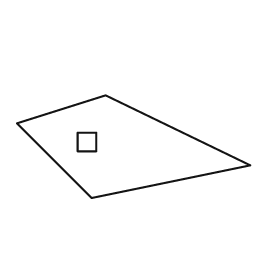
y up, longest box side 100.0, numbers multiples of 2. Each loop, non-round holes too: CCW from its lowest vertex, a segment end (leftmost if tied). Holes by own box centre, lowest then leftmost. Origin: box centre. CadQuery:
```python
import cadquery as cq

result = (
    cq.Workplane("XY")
    .moveTo(-18.0, -22.0)
    .lineTo(50.0, -8.0)
    .lineTo(-12.0, 22.0)
    .lineTo(-50.0, 10.0)
    .close()
    .moveTo(-24.0, -2.0)
    .lineTo(-16.0, -2.0)
    .lineTo(-16.0, 6.0)
    .lineTo(-24.0, 6.0)
    .close()
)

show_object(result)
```